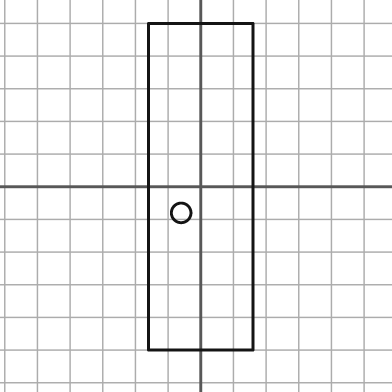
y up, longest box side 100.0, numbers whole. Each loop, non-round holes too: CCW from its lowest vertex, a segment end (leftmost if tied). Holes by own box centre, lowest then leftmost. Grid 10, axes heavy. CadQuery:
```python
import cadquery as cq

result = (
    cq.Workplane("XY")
    .moveTo(-16.0, -50.0)
    .lineTo(16.0, -50.0)
    .lineTo(16.0, 50.0)
    .lineTo(-16.0, 50.0)
    .close()
    .moveTo(-6.0, -8.0)
    .circle(3.0)
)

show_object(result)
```